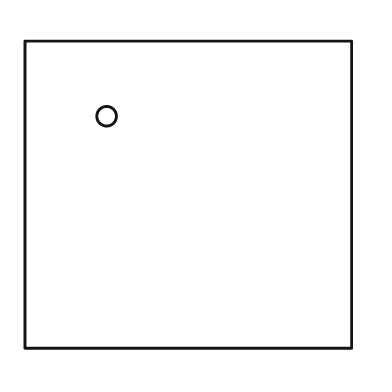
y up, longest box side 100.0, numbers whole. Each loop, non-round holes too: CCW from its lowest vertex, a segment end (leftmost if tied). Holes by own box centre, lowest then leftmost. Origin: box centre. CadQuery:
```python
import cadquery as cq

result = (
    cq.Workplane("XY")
    .moveTo(-50.0, -47.0)
    .lineTo(50.0, -47.0)
    .lineTo(50.0, 47.0)
    .lineTo(-50.0, 47.0)
    .close()
    .moveTo(-25.0, 24.0)
    .circle(3.0)
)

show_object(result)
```